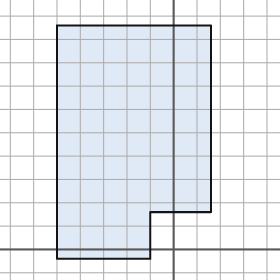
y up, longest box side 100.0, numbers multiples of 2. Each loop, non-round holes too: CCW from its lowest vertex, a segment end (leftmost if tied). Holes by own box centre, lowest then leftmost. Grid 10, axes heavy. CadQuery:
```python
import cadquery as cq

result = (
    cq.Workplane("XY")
    .moveTo(-50.0, -4.0)
    .lineTo(-10.0, -4.0)
    .lineTo(-10.0, 16.0)
    .lineTo(16.0, 16.0)
    .lineTo(16.0, 96.0)
    .lineTo(-50.0, 96.0)
    .close()
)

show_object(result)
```